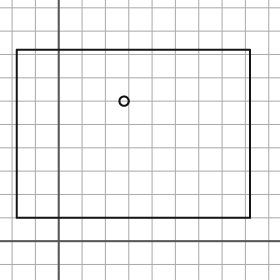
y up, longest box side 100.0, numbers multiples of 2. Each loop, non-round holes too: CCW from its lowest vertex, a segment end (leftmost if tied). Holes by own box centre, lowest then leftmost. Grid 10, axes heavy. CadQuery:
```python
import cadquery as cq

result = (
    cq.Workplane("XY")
    .moveTo(-18.0, 10.0)
    .lineTo(82.0, 10.0)
    .lineTo(82.0, 82.0)
    .lineTo(-18.0, 82.0)
    .close()
    .moveTo(28.0, 60.0)
    .circle(2.0)
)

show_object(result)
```